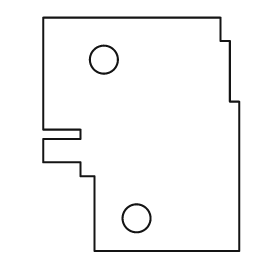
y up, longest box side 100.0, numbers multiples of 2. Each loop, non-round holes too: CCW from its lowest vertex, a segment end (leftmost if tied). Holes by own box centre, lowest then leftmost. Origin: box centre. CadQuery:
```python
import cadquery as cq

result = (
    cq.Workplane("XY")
    .moveTo(-20.0, -50.0)
    .lineTo(42.0, -50.0)
    .lineTo(42.0, 14.0)
    .lineTo(38.0, 14.0)
    .lineTo(38.0, 40.0)
    .lineTo(34.0, 40.0)
    .lineTo(34.0, 50.0)
    .lineTo(-42.0, 50.0)
    .lineTo(-42.0, 2.0)
    .lineTo(-26.0, 2.0)
    .lineTo(-26.0, -2.0)
    .lineTo(-42.0, -2.0)
    .lineTo(-42.0, -12.0)
    .lineTo(-26.0, -12.0)
    .lineTo(-26.0, -18.0)
    .lineTo(-20.0, -18.0)
    .close()
    .moveTo(-2.0, -36.0)
    .circle(6.0)
    .moveTo(-16.0, 32.0)
    .circle(6.0)
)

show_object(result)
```